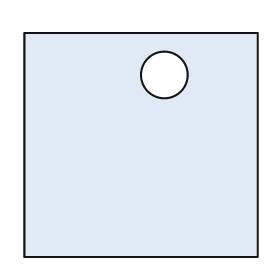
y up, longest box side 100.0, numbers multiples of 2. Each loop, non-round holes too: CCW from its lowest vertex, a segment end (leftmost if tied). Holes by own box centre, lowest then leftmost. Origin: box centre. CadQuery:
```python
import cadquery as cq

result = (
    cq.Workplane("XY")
    .moveTo(-50.0, -48.0)
    .lineTo(50.0, -48.0)
    .lineTo(50.0, 48.0)
    .lineTo(-50.0, 48.0)
    .close()
    .moveTo(10.0, 30.0)
    .circle(10.0)
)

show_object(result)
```